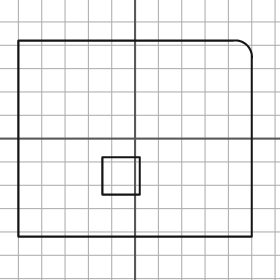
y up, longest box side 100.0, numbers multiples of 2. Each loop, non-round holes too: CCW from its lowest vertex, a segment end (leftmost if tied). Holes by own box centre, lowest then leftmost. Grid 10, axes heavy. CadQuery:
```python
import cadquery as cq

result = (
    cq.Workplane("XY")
    .moveTo(-50.0, -42.0)
    .lineTo(50.0, -42.0)
    .lineTo(50.0, 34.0)
    .threePointArc((48.0, 40.0), (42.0, 42.0))
    .lineTo(-50.0, 42.0)
    .close()
    .moveTo(-14.0, -24.0)
    .lineTo(2.0, -24.0)
    .lineTo(2.0, -8.0)
    .lineTo(-14.0, -8.0)
    .close()
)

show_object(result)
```